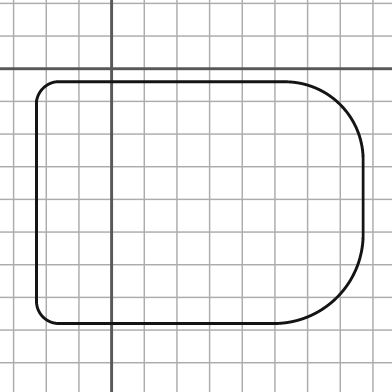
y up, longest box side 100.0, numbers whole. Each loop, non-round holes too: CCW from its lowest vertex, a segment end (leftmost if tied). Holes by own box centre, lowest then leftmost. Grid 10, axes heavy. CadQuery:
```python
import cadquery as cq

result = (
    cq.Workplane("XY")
    .moveTo(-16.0, -78.0)
    .lineTo(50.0, -78.0)
    .threePointArc((69.0, -70.0), (77.0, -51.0))
    .lineTo(77.0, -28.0)
    .threePointArc((70.0, -11.0), (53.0, -4.0))
    .lineTo(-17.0, -4.0)
    .threePointArc((-21.0, -6.0), (-23.0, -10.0))
    .lineTo(-23.0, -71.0)
    .threePointArc((-21.0, -76.0), (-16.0, -78.0))
    .close()
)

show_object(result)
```